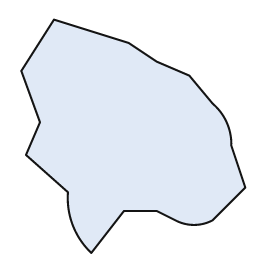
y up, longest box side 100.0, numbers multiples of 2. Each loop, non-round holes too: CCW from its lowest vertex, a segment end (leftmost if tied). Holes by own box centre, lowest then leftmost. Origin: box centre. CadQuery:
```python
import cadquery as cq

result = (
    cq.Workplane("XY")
    .moveTo(-18.0, -50.0)
    .lineTo(-4.0, -32.0)
    .lineTo(10.0, -32.0)
    .lineTo(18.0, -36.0)
    .threePointArc((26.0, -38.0), (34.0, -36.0))
    .lineTo(48.0, -22.0)
    .lineTo(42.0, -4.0)
    .threePointArc((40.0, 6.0), (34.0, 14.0))
    .lineTo(24.0, 26.0)
    .lineTo(10.0, 32.0)
    .lineTo(-2.0, 40.0)
    .lineTo(-34.0, 50.0)
    .lineTo(-48.0, 28.0)
    .lineTo(-40.0, 6.0)
    .lineTo(-46.0, -8.0)
    .lineTo(-28.0, -24.0)
    .threePointArc((-26.0, -38.0), (-18.0, -50.0))
    .close()
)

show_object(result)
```